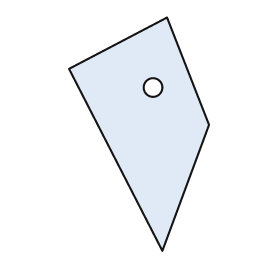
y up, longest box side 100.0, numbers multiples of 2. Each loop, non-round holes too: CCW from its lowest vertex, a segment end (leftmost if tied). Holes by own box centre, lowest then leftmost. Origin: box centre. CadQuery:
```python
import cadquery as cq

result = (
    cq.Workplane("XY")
    .moveTo(10.0, -50.0)
    .lineTo(30.0, 4.0)
    .lineTo(12.0, 50.0)
    .lineTo(-30.0, 28.0)
    .close()
    .moveTo(6.0, 20.0)
    .circle(4.0)
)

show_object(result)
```